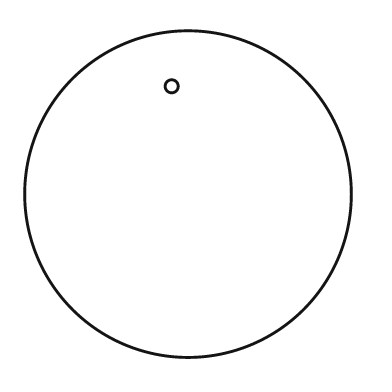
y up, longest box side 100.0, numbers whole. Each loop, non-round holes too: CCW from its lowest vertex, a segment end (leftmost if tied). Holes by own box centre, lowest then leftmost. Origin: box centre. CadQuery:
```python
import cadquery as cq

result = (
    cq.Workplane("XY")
    .moveTo(0.0, 0.0)
    .circle(50.0)
    .moveTo(-5.0, 33.0)
    .circle(2.0)
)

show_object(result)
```